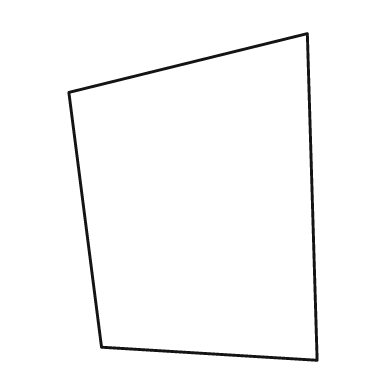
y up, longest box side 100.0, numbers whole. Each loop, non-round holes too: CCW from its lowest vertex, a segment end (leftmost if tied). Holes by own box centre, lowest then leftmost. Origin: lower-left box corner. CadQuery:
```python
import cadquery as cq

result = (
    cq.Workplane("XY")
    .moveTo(76.0, 0.0)
    .lineTo(73.0, 100.0)
    .lineTo(0.0, 82.0)
    .lineTo(10.0, 4.0)
    .close()
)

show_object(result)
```